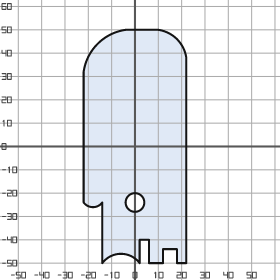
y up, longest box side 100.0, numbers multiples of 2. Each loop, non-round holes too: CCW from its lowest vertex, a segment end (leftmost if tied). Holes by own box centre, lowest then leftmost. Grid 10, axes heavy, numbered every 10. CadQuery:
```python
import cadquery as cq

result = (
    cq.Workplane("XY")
    .moveTo(-14.0, -50.0)
    .threePointArc((-6.0, -46.0), (2.0, -50.0))
    .lineTo(2.0, -40.0)
    .lineTo(6.0, -40.0)
    .lineTo(6.0, -50.0)
    .lineTo(12.0, -50.0)
    .lineTo(12.0, -44.0)
    .lineTo(18.0, -44.0)
    .lineTo(18.0, -50.0)
    .lineTo(22.0, -50.0)
    .lineTo(22.0, 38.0)
    .threePointArc((18.0, 46.0), (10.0, 50.0))
    .lineTo(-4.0, 50.0)
    .threePointArc((-16.0, 44.0), (-22.0, 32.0))
    .lineTo(-22.0, -24.0)
    .threePointArc((-18.0, -26.0), (-14.0, -24.0))
    .close()
    .moveTo(0.0, -24.0)
    .circle(4.0)
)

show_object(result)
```